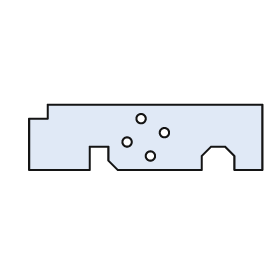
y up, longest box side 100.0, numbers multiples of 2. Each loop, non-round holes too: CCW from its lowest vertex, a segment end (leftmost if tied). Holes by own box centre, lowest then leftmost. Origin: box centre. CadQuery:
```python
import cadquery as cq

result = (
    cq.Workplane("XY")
    .moveTo(-50.0, -14.0)
    .lineTo(-24.0, -14.0)
    .lineTo(-24.0, -4.0)
    .lineTo(-16.0, -4.0)
    .lineTo(-16.0, -10.0)
    .lineTo(-12.0, -14.0)
    .lineTo(24.0, -14.0)
    .lineTo(24.0, -8.0)
    .lineTo(28.0, -4.0)
    .lineTo(34.0, -4.0)
    .lineTo(38.0, -8.0)
    .lineTo(38.0, -14.0)
    .lineTo(50.0, -14.0)
    .lineTo(50.0, 14.0)
    .lineTo(-42.0, 14.0)
    .lineTo(-42.0, 8.0)
    .lineTo(-50.0, 8.0)
    .close()
    .moveTo(2.0, -8.0)
    .circle(2.0)
    .moveTo(-8.0, -2.0)
    .circle(2.0)
    .moveTo(8.0, 2.0)
    .circle(2.0)
    .moveTo(-2.0, 8.0)
    .circle(2.0)
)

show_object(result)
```